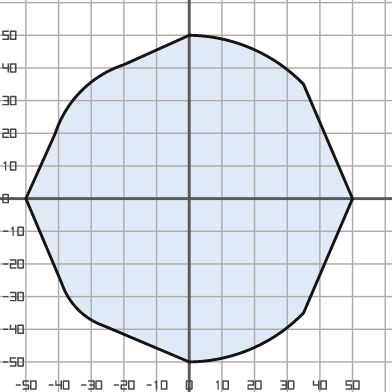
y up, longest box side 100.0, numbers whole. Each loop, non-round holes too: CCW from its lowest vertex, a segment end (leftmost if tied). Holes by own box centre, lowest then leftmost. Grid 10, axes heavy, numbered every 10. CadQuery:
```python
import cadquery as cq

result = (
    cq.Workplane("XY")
    .moveTo(0.0, -50.0)
    .threePointArc((19.0, -46.0), (35.0, -35.0))
    .lineTo(50.0, 0.0)
    .lineTo(35.0, 35.0)
    .threePointArc((19.0, 46.0), (0.0, 50.0))
    .lineTo(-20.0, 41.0)
    .threePointArc((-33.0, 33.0), (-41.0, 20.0))
    .lineTo(-50.0, 0.0)
    .lineTo(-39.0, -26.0)
    .threePointArc((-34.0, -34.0), (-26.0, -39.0))
    .close()
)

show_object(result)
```